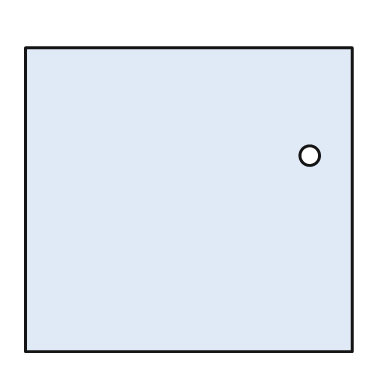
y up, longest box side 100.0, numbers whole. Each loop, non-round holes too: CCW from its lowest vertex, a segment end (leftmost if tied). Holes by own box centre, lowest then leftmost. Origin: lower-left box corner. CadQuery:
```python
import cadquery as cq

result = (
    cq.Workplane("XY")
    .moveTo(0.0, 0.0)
    .lineTo(100.0, 0.0)
    .lineTo(100.0, 93.0)
    .lineTo(0.0, 93.0)
    .close()
    .moveTo(87.0, 60.0)
    .circle(3.0)
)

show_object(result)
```